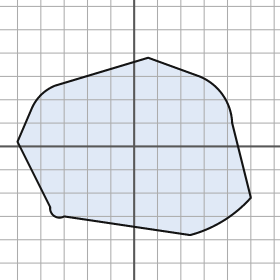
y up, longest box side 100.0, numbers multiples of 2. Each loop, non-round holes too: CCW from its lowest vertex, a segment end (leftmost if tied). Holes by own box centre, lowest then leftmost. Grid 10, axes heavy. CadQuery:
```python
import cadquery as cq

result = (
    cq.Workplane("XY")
    .moveTo(24.0, -38.0)
    .threePointArc((38.0, -32.0), (50.0, -22.0))
    .lineTo(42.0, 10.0)
    .threePointArc((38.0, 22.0), (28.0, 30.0))
    .lineTo(6.0, 38.0)
    .lineTo(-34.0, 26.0)
    .threePointArc((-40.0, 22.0), (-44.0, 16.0))
    .lineTo(-50.0, 2.0)
    .lineTo(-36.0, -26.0)
    .threePointArc((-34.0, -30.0), (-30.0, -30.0))
    .close()
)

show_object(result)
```